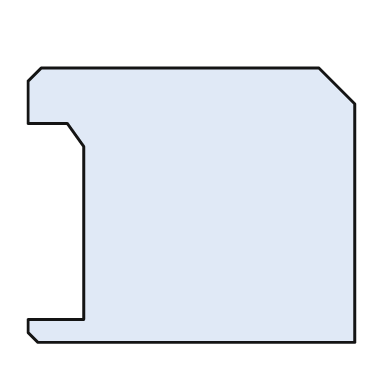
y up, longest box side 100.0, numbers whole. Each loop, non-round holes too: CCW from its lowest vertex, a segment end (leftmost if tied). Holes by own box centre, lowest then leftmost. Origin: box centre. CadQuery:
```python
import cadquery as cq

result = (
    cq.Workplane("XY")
    .moveTo(-47.0, -42.0)
    .lineTo(50.0, -42.0)
    .lineTo(50.0, 31.0)
    .lineTo(39.0, 42.0)
    .lineTo(-46.0, 42.0)
    .lineTo(-50.0, 38.0)
    .lineTo(-50.0, 25.0)
    .lineTo(-38.0, 25.0)
    .lineTo(-33.0, 18.0)
    .lineTo(-33.0, -35.0)
    .lineTo(-50.0, -35.0)
    .lineTo(-50.0, -39.0)
    .close()
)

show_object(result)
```